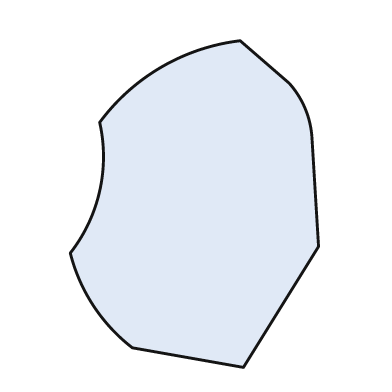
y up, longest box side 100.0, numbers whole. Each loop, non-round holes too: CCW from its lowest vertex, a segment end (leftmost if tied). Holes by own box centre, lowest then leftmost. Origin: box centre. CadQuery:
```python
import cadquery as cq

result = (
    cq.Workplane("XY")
    .moveTo(15.0, -50.0)
    .lineTo(38.0, -13.0)
    .lineTo(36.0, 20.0)
    .threePointArc((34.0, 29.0), (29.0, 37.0))
    .lineTo(14.0, 50.0)
    .threePointArc((-10.0, 42.0), (-29.0, 25.0))
    .threePointArc((-29.0, 4.0), (-38.0, -15.0))
    .threePointArc((-31.0, -31.0), (-19.0, -44.0))
    .close()
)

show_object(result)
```